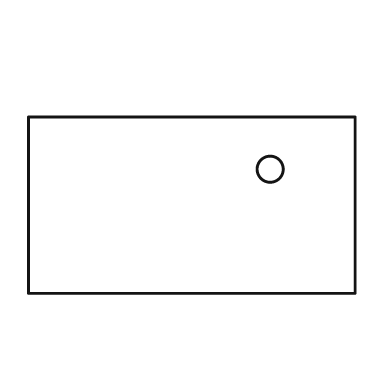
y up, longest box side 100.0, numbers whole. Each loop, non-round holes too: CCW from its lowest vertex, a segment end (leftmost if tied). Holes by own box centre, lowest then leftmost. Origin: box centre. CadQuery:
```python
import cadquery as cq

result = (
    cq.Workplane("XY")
    .moveTo(-50.0, -27.0)
    .lineTo(50.0, -27.0)
    .lineTo(50.0, 27.0)
    .lineTo(-50.0, 27.0)
    .close()
    .moveTo(24.0, 11.0)
    .circle(4.0)
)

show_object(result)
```